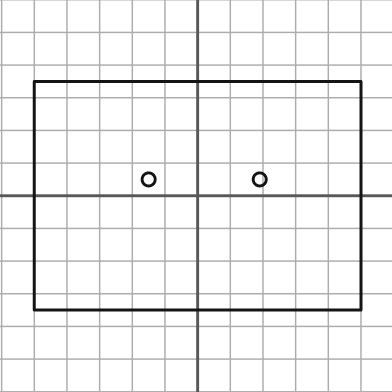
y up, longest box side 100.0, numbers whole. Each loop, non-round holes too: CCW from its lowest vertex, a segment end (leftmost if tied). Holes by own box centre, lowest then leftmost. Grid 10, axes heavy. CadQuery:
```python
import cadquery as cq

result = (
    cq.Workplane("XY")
    .moveTo(-50.0, -35.0)
    .lineTo(50.0, -35.0)
    .lineTo(50.0, 35.0)
    .lineTo(-50.0, 35.0)
    .close()
    .moveTo(-15.0, 5.0)
    .circle(2.0)
    .moveTo(19.0, 5.0)
    .circle(2.0)
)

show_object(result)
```